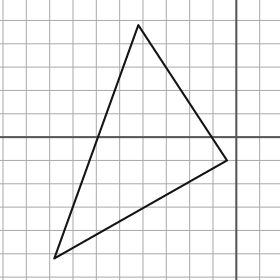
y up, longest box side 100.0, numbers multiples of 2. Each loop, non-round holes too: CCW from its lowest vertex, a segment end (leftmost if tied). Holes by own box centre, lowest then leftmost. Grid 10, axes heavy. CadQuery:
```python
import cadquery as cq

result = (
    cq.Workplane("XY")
    .moveTo(-78.0, -52.0)
    .lineTo(-4.0, -10.0)
    .lineTo(-42.0, 48.0)
    .close()
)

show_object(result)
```